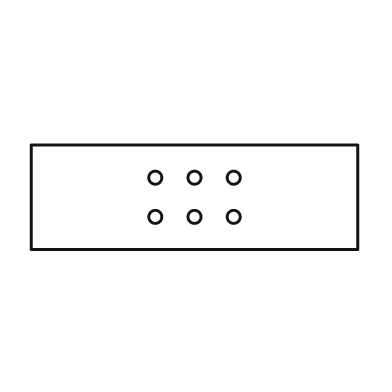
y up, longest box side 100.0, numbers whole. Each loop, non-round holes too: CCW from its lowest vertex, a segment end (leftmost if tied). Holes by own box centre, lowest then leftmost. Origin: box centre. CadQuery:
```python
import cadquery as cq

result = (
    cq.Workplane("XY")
    .moveTo(-50.0, -16.0)
    .lineTo(50.0, -16.0)
    .lineTo(50.0, 16.0)
    .lineTo(-50.0, 16.0)
    .close()
    .moveTo(-12.0, -6.0)
    .circle(2.0)
    .moveTo(0.0, -6.0)
    .circle(2.0)
    .moveTo(12.0, -6.0)
    .circle(2.0)
    .moveTo(-12.0, 6.0)
    .circle(2.0)
    .moveTo(0.0, 6.0)
    .circle(2.0)
    .moveTo(12.0, 6.0)
    .circle(2.0)
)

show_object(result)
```